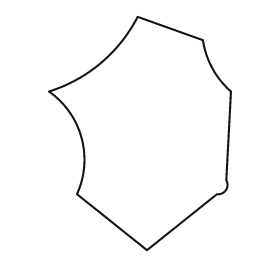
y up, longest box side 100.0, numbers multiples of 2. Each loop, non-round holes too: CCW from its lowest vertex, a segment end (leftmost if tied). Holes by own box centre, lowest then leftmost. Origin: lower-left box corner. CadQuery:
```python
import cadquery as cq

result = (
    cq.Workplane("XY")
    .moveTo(42.0, 0.0)
    .lineTo(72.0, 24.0)
    .threePointArc((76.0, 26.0), (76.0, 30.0))
    .lineTo(78.0, 68.0)
    .threePointArc((70.0, 78.0), (66.0, 90.0))
    .lineTo(38.0, 100.0)
    .threePointArc((22.0, 80.0), (0.0, 68.0))
    .threePointArc((14.0, 48.0), (12.0, 24.0))
    .close()
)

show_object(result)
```